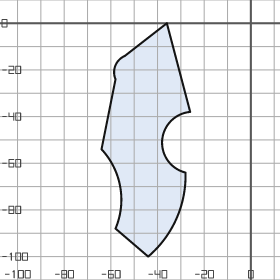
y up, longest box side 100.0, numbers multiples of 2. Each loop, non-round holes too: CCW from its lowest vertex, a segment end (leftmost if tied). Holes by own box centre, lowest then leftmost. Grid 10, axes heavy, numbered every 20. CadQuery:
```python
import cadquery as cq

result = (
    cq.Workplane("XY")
    .moveTo(-44.0, -100.0)
    .threePointArc((-32.0, -84.0), (-28.0, -64.0))
    .threePointArc((-38.0, -50.0), (-26.0, -38.0))
    .lineTo(-36.0, 0.0)
    .lineTo(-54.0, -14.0)
    .threePointArc((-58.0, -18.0), (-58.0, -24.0))
    .lineTo(-64.0, -54.0)
    .threePointArc((-56.0, -70.0), (-58.0, -88.0))
    .close()
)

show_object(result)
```